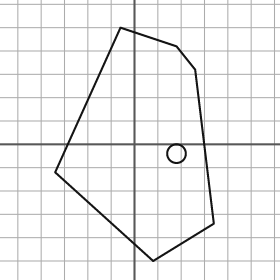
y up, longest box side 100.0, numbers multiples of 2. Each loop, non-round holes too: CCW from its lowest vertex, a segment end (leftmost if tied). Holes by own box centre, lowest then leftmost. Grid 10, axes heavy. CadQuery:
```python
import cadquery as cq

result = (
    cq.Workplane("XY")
    .moveTo(8.0, -50.0)
    .lineTo(34.0, -34.0)
    .lineTo(26.0, 32.0)
    .lineTo(18.0, 42.0)
    .lineTo(-6.0, 50.0)
    .lineTo(-34.0, -12.0)
    .close()
    .moveTo(18.0, -4.0)
    .circle(4.0)
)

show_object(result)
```